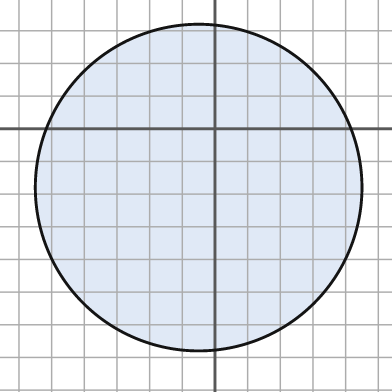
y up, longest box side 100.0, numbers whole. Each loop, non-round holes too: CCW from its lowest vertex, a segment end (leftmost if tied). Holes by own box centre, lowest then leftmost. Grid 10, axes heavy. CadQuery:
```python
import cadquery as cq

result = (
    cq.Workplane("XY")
    .moveTo(-5.0, -18.0)
    .circle(50.0)
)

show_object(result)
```